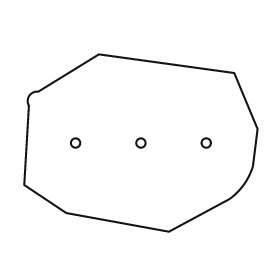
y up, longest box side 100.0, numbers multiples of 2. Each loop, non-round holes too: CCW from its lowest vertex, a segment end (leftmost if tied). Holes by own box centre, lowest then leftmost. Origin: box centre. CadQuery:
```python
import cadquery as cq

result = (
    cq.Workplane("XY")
    .moveTo(12.0, -38.0)
    .lineTo(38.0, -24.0)
    .threePointArc((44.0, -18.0), (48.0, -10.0))
    .lineTo(50.0, 6.0)
    .lineTo(40.0, 30.0)
    .lineTo(-18.0, 38.0)
    .lineTo(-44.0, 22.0)
    .threePointArc((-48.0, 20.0), (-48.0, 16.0))
    .lineTo(-50.0, -18.0)
    .lineTo(-32.0, -30.0)
    .close()
    .moveTo(-28.0, 0.0)
    .circle(2.0)
    .moveTo(0.0, 0.0)
    .circle(2.0)
    .moveTo(28.0, 0.0)
    .circle(2.0)
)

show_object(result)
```